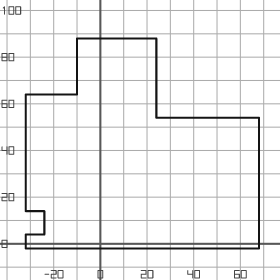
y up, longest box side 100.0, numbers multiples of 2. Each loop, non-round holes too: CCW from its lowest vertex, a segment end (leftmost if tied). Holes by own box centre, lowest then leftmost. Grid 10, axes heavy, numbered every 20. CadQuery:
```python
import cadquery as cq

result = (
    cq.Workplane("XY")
    .moveTo(-32.0, -2.0)
    .lineTo(68.0, -2.0)
    .lineTo(68.0, 54.0)
    .lineTo(24.0, 54.0)
    .lineTo(24.0, 88.0)
    .lineTo(-10.0, 88.0)
    .lineTo(-10.0, 64.0)
    .lineTo(-32.0, 64.0)
    .lineTo(-32.0, 14.0)
    .lineTo(-24.0, 14.0)
    .lineTo(-24.0, 4.0)
    .lineTo(-32.0, 4.0)
    .close()
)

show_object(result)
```